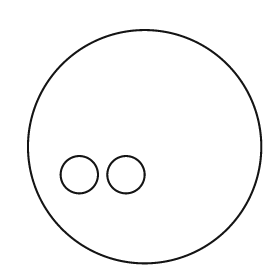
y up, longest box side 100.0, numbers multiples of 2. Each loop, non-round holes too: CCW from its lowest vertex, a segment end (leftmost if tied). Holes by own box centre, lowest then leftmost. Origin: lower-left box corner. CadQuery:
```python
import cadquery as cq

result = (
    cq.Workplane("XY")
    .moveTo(50.0, 50.0)
    .circle(50.0)
    .moveTo(22.0, 38.0)
    .circle(8.0)
    .moveTo(42.0, 38.0)
    .circle(8.0)
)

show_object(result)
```